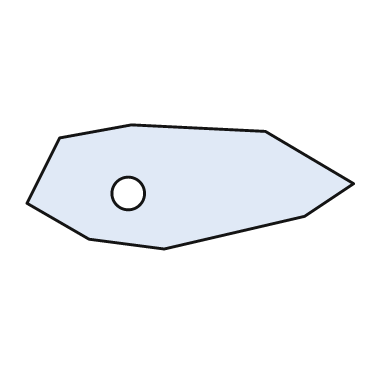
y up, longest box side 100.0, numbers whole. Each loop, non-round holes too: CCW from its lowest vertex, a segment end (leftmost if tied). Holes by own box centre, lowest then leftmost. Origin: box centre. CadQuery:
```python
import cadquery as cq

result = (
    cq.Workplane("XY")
    .moveTo(-8.0, -19.0)
    .lineTo(35.0, -9.0)
    .lineTo(50.0, 1.0)
    .lineTo(23.0, 17.0)
    .lineTo(-18.0, 19.0)
    .lineTo(-40.0, 15.0)
    .lineTo(-50.0, -5.0)
    .lineTo(-31.0, -16.0)
    .close()
    .moveTo(-19.0, -2.0)
    .circle(5.0)
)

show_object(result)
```